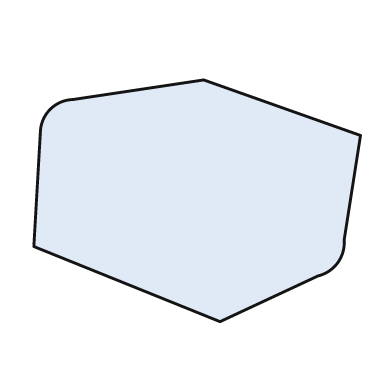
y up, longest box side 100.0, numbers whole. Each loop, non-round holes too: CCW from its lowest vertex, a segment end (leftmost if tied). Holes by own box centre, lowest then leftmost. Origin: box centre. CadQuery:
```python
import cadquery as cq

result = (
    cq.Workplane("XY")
    .moveTo(7.0, -37.0)
    .lineTo(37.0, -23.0)
    .threePointArc((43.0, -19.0), (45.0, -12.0))
    .lineTo(50.0, 20.0)
    .lineTo(2.0, 37.0)
    .lineTo(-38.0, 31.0)
    .threePointArc((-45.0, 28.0), (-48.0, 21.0))
    .lineTo(-50.0, -14.0)
    .close()
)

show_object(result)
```